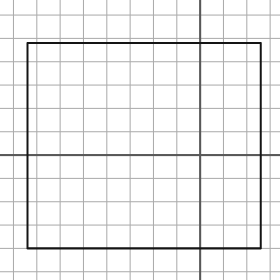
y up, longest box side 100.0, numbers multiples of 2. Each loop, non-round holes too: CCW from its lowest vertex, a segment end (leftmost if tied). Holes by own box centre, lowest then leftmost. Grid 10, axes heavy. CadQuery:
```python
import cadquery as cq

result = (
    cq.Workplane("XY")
    .moveTo(-74.0, -40.0)
    .lineTo(26.0, -40.0)
    .lineTo(26.0, 48.0)
    .lineTo(-74.0, 48.0)
    .close()
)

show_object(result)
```